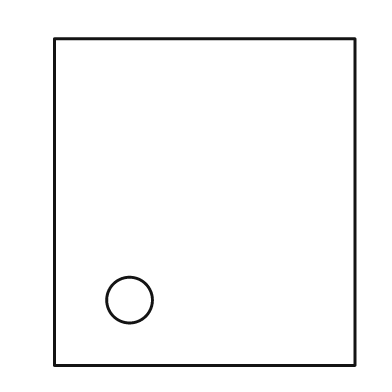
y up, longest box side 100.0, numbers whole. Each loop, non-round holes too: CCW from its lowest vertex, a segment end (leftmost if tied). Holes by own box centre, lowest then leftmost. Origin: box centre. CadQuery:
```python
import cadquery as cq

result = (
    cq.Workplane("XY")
    .moveTo(-46.0, -50.0)
    .lineTo(46.0, -50.0)
    .lineTo(46.0, 50.0)
    .lineTo(-46.0, 50.0)
    .close()
    .moveTo(-23.0, -30.0)
    .circle(7.0)
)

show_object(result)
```